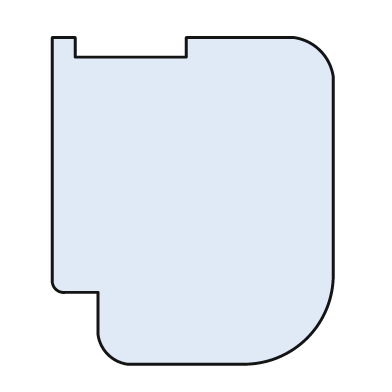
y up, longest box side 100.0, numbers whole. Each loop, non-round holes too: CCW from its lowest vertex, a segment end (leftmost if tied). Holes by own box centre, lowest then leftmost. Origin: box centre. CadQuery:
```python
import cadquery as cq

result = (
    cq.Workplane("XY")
    .moveTo(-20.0, -50.0)
    .lineTo(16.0, -50.0)
    .threePointArc((35.0, -42.0), (43.0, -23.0))
    .lineTo(43.0, 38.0)
    .threePointArc((39.0, 46.0), (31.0, 50.0))
    .lineTo(-2.0, 50.0)
    .lineTo(-2.0, 44.0)
    .lineTo(-36.0, 44.0)
    .lineTo(-36.0, 50.0)
    .lineTo(-43.0, 50.0)
    .lineTo(-43.0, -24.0)
    .threePointArc((-42.0, -27.0), (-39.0, -28.0))
    .lineTo(-29.0, -28.0)
    .lineTo(-29.0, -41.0)
    .threePointArc((-26.0, -47.0), (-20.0, -50.0))
    .close()
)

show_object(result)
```